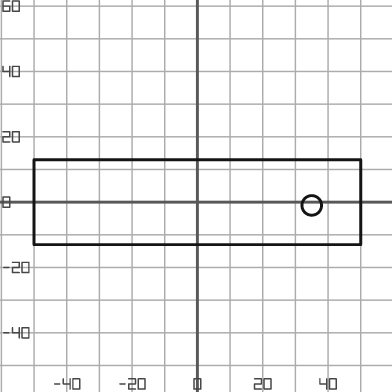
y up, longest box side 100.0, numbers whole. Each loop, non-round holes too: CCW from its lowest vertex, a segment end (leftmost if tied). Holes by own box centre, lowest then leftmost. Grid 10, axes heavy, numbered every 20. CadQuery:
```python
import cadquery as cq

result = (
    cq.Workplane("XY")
    .moveTo(-50.0, -13.0)
    .lineTo(50.0, -13.0)
    .lineTo(50.0, 13.0)
    .lineTo(-50.0, 13.0)
    .close()
    .moveTo(35.0, -1.0)
    .circle(3.0)
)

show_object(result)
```